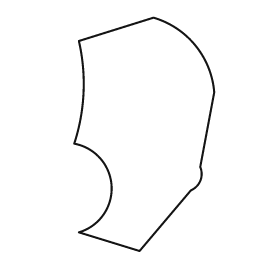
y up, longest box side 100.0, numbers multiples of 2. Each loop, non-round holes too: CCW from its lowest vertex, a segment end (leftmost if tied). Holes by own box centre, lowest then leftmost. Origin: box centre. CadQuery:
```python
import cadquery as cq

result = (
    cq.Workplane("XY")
    .moveTo(-2.0, -50.0)
    .lineTo(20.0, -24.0)
    .threePointArc((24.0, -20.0), (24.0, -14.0))
    .lineTo(30.0, 18.0)
    .threePointArc((22.0, 38.0), (4.0, 50.0))
    .lineTo(-28.0, 40.0)
    .threePointArc((-26.0, 18.0), (-30.0, -4.0))
    .threePointArc((-14.0, -22.0), (-28.0, -42.0))
    .close()
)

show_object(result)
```